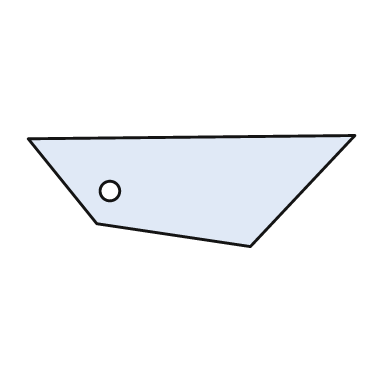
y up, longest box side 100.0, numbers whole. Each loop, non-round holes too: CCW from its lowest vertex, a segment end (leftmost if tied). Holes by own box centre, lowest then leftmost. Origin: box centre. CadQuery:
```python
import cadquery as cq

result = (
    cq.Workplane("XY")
    .moveTo(18.0, -17.0)
    .lineTo(50.0, 17.0)
    .lineTo(-50.0, 16.0)
    .lineTo(-29.0, -10.0)
    .close()
    .moveTo(-25.0, 0.0)
    .circle(3.0)
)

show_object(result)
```